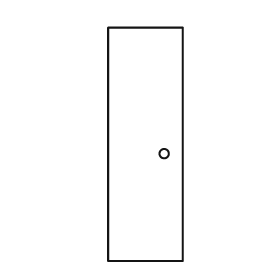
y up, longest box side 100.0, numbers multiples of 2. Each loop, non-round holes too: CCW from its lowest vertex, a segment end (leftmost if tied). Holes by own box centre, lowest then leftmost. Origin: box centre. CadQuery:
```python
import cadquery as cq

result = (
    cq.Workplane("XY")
    .moveTo(-16.0, -50.0)
    .lineTo(16.0, -50.0)
    .lineTo(16.0, 50.0)
    .lineTo(-16.0, 50.0)
    .close()
    .moveTo(8.0, -4.0)
    .circle(2.0)
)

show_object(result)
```